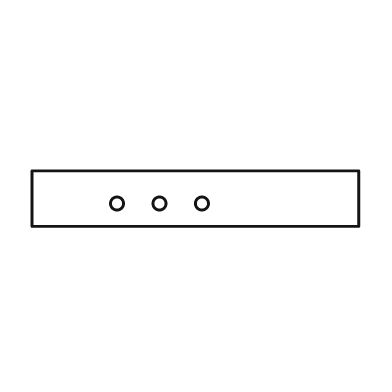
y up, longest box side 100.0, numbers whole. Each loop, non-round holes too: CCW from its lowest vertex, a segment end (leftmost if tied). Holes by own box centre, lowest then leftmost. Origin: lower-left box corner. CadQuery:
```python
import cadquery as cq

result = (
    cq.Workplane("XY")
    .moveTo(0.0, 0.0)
    .lineTo(100.0, 0.0)
    .lineTo(100.0, 17.0)
    .lineTo(0.0, 17.0)
    .close()
    .moveTo(26.0, 7.0)
    .circle(2.0)
    .moveTo(39.0, 7.0)
    .circle(2.0)
    .moveTo(52.0, 7.0)
    .circle(2.0)
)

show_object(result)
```